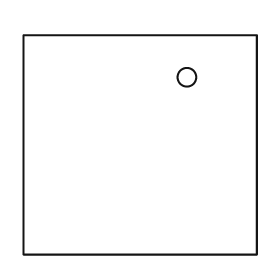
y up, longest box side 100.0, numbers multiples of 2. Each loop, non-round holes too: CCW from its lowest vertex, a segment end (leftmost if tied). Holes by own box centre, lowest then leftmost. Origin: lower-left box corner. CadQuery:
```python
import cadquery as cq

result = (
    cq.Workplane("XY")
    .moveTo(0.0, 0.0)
    .lineTo(100.0, 0.0)
    .lineTo(100.0, 94.0)
    .lineTo(0.0, 94.0)
    .close()
    .moveTo(70.0, 76.0)
    .circle(4.0)
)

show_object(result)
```